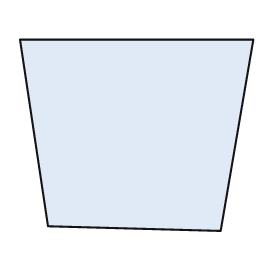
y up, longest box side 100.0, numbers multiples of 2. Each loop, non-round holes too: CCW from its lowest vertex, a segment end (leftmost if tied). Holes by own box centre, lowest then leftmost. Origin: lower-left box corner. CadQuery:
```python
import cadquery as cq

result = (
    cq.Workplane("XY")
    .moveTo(86.0, 0.0)
    .lineTo(100.0, 82.0)
    .lineTo(0.0, 82.0)
    .lineTo(12.0, 2.0)
    .close()
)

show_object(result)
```